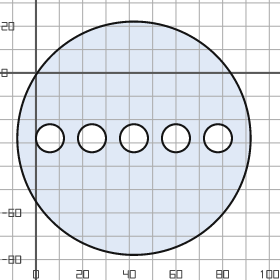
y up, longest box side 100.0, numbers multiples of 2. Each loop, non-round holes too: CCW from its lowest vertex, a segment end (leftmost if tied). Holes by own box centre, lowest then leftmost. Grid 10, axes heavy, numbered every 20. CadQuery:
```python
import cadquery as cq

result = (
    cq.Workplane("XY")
    .moveTo(42.0, -28.0)
    .circle(50.0)
    .moveTo(6.0, -28.0)
    .circle(6.0)
    .moveTo(24.0, -28.0)
    .circle(6.0)
    .moveTo(42.0, -28.0)
    .circle(6.0)
    .moveTo(60.0, -28.0)
    .circle(6.0)
    .moveTo(78.0, -28.0)
    .circle(6.0)
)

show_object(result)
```